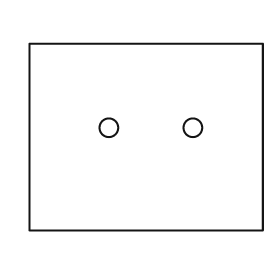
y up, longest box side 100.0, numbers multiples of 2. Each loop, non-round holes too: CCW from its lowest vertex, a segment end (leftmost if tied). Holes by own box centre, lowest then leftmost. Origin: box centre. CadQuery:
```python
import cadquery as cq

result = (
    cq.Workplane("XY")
    .moveTo(-50.0, -40.0)
    .lineTo(50.0, -40.0)
    .lineTo(50.0, 40.0)
    .lineTo(-50.0, 40.0)
    .close()
    .moveTo(-16.0, 4.0)
    .circle(4.0)
    .moveTo(20.0, 4.0)
    .circle(4.0)
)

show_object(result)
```